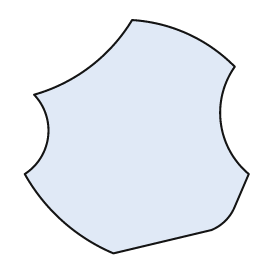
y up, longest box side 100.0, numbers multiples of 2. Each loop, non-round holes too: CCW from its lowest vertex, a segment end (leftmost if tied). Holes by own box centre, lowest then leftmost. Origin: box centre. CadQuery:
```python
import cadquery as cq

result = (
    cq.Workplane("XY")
    .moveTo(-10.0, -50.0)
    .lineTo(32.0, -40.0)
    .threePointArc((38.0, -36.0), (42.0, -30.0))
    .lineTo(48.0, -16.0)
    .threePointArc((36.0, 6.0), (42.0, 30.0))
    .threePointArc((22.0, 44.0), (-2.0, 50.0))
    .threePointArc((-20.0, 30.0), (-44.0, 18.0))
    .threePointArc((-38.0, 0.0), (-48.0, -16.0))
    .threePointArc((-32.0, -36.0), (-10.0, -50.0))
    .close()
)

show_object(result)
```